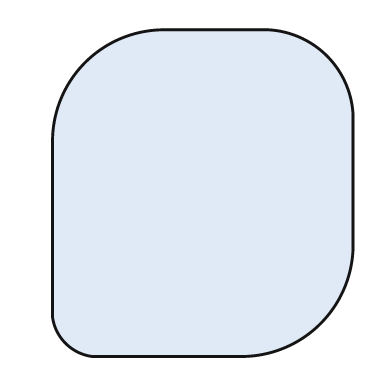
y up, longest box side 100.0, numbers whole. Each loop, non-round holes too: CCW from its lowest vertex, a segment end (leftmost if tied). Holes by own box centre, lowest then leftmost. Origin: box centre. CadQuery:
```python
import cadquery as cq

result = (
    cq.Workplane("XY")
    .moveTo(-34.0, -50.0)
    .lineTo(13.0, -50.0)
    .threePointArc((36.0, -40.0), (46.0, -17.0))
    .lineTo(46.0, 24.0)
    .threePointArc((38.0, 42.0), (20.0, 50.0))
    .lineTo(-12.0, 50.0)
    .threePointArc((-36.0, 40.0), (-46.0, 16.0))
    .lineTo(-46.0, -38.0)
    .threePointArc((-42.0, -46.0), (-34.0, -50.0))
    .close()
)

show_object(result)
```